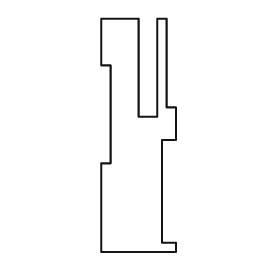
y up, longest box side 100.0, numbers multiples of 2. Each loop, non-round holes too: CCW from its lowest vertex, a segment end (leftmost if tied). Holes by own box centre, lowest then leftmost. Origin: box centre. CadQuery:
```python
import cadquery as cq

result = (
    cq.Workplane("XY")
    .moveTo(-16.0, -50.0)
    .lineTo(16.0, -50.0)
    .lineTo(16.0, -46.0)
    .lineTo(10.0, -46.0)
    .lineTo(10.0, -2.0)
    .lineTo(16.0, -2.0)
    .lineTo(16.0, 12.0)
    .lineTo(12.0, 12.0)
    .lineTo(12.0, 50.0)
    .lineTo(8.0, 50.0)
    .lineTo(8.0, 8.0)
    .lineTo(0.0, 8.0)
    .lineTo(0.0, 50.0)
    .lineTo(-16.0, 50.0)
    .lineTo(-16.0, 30.0)
    .lineTo(-12.0, 30.0)
    .lineTo(-12.0, -12.0)
    .lineTo(-16.0, -12.0)
    .close()
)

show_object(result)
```